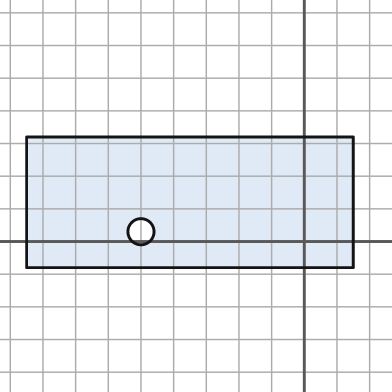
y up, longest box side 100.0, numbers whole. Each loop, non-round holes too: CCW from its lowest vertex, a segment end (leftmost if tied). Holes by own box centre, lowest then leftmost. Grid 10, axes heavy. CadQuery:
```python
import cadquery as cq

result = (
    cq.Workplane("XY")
    .moveTo(-85.0, -8.0)
    .lineTo(15.0, -8.0)
    .lineTo(15.0, 32.0)
    .lineTo(-85.0, 32.0)
    .close()
    .moveTo(-50.0, 3.0)
    .circle(4.0)
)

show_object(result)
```